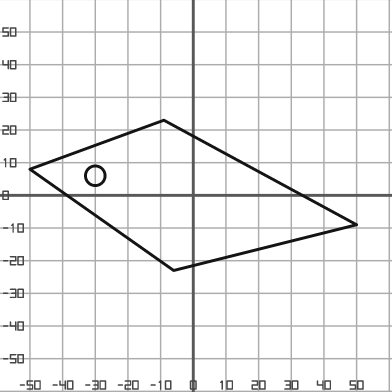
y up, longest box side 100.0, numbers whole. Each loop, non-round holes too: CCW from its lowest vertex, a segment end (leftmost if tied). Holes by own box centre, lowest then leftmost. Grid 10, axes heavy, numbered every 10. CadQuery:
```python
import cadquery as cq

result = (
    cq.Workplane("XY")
    .moveTo(-6.0, -23.0)
    .lineTo(50.0, -9.0)
    .lineTo(-9.0, 23.0)
    .lineTo(-50.0, 8.0)
    .close()
    .moveTo(-30.0, 6.0)
    .circle(3.0)
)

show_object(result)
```